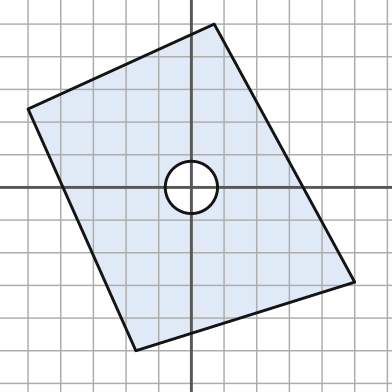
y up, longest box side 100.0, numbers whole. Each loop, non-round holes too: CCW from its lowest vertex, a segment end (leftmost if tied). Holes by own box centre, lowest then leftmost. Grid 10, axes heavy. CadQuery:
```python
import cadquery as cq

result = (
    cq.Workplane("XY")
    .moveTo(-17.0, -50.0)
    .lineTo(50.0, -29.0)
    .lineTo(7.0, 50.0)
    .lineTo(-50.0, 24.0)
    .close()
    .moveTo(0.0, 0.0)
    .circle(8.0)
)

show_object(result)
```